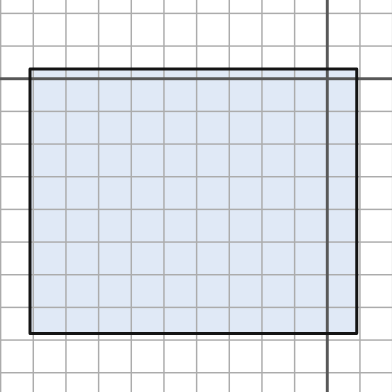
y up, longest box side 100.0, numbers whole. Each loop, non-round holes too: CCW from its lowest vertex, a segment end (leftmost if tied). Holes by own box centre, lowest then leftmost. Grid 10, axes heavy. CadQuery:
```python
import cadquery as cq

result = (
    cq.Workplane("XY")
    .moveTo(-91.0, -78.0)
    .lineTo(9.0, -78.0)
    .lineTo(9.0, 3.0)
    .lineTo(-91.0, 3.0)
    .close()
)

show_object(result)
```